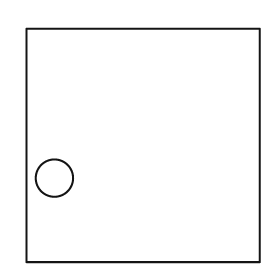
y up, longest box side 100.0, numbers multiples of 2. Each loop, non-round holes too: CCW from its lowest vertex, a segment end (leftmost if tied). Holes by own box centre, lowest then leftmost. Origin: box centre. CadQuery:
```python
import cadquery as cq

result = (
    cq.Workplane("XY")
    .moveTo(-50.0, -50.0)
    .lineTo(50.0, -50.0)
    .lineTo(50.0, 50.0)
    .lineTo(-50.0, 50.0)
    .close()
    .moveTo(-38.0, -14.0)
    .circle(8.0)
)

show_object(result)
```